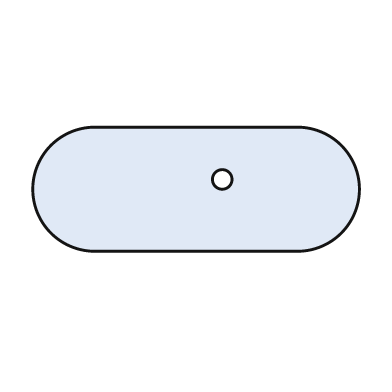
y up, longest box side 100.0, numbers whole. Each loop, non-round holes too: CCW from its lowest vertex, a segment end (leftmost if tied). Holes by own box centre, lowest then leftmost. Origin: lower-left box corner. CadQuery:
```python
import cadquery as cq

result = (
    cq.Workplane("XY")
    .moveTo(19.0, 0.0)
    .lineTo(81.0, 0.0)
    .threePointArc((100.0, 19.0), (81.0, 38.0))
    .lineTo(19.0, 38.0)
    .threePointArc((0.0, 19.0), (19.0, 0.0))
    .close()
    .moveTo(58.0, 22.0)
    .circle(3.0)
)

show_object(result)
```